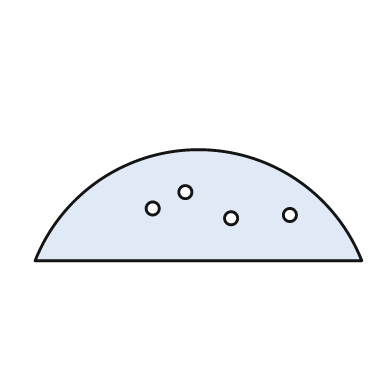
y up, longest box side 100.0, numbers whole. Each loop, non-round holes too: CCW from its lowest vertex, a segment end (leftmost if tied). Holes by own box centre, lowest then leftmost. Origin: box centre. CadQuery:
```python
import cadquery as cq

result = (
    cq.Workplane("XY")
    .moveTo(-50.0, -17.0)
    .lineTo(50.0, -17.0)
    .threePointArc((0.0, 17.0), (-50.0, -17.0))
    .close()
    .moveTo(10.0, -4.0)
    .circle(2.0)
    .moveTo(28.0, -3.0)
    .circle(2.0)
    .moveTo(-14.0, -1.0)
    .circle(2.0)
    .moveTo(-4.0, 4.0)
    .circle(2.0)
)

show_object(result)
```